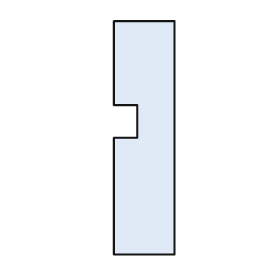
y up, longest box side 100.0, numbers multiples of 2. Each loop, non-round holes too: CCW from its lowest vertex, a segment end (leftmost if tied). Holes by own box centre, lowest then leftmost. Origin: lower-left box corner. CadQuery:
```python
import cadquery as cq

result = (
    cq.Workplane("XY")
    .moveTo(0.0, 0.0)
    .lineTo(26.0, 0.0)
    .lineTo(26.0, 100.0)
    .lineTo(0.0, 100.0)
    .lineTo(0.0, 64.0)
    .lineTo(10.0, 64.0)
    .lineTo(10.0, 50.0)
    .lineTo(0.0, 50.0)
    .close()
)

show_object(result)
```